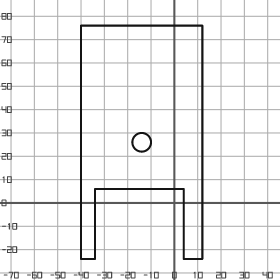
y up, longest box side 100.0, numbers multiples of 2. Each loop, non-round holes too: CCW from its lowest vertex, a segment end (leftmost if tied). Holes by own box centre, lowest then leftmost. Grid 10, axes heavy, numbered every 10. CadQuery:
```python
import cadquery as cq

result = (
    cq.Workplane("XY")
    .moveTo(-40.0, -24.0)
    .lineTo(-34.0, -24.0)
    .lineTo(-34.0, 6.0)
    .lineTo(4.0, 6.0)
    .lineTo(4.0, -24.0)
    .lineTo(12.0, -24.0)
    .lineTo(12.0, 76.0)
    .lineTo(-40.0, 76.0)
    .close()
    .moveTo(-14.0, 26.0)
    .circle(4.0)
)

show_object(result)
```